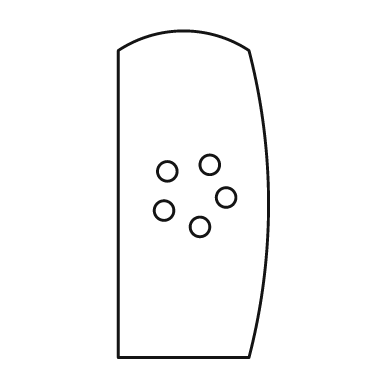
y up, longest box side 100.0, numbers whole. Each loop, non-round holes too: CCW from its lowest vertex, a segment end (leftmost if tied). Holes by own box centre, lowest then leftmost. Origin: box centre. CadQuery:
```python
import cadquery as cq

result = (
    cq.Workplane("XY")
    .moveTo(-23.0, -50.0)
    .lineTo(17.0, -50.0)
    .threePointArc((23.0, -3.0), (17.0, 44.0))
    .threePointArc((-3.0, 50.0), (-23.0, 44.0))
    .close()
    .moveTo(2.0, -10.0)
    .circle(3.0)
    .moveTo(-9.0, -5.0)
    .circle(3.0)
    .moveTo(10.0, -1.0)
    .circle(3.0)
    .moveTo(-8.0, 7.0)
    .circle(3.0)
    .moveTo(5.0, 9.0)
    .circle(3.0)
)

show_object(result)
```